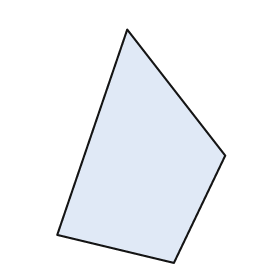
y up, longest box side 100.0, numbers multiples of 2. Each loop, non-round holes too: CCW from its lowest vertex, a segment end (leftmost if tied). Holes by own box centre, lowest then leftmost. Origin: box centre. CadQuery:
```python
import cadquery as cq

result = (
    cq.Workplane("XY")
    .moveTo(14.0, -50.0)
    .lineTo(36.0, -4.0)
    .lineTo(-6.0, 50.0)
    .lineTo(-36.0, -38.0)
    .close()
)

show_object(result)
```